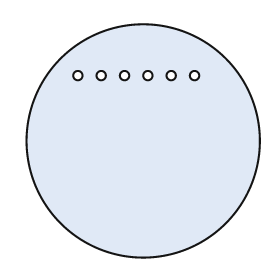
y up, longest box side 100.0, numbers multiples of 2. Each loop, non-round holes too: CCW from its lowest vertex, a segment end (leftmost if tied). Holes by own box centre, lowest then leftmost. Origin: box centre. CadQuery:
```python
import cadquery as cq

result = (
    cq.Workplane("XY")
    .moveTo(0.0, 0.0)
    .circle(50.0)
    .moveTo(-28.0, 28.0)
    .circle(2.0)
    .moveTo(-18.0, 28.0)
    .circle(2.0)
    .moveTo(-8.0, 28.0)
    .circle(2.0)
    .moveTo(2.0, 28.0)
    .circle(2.0)
    .moveTo(12.0, 28.0)
    .circle(2.0)
    .moveTo(22.0, 28.0)
    .circle(2.0)
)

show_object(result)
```